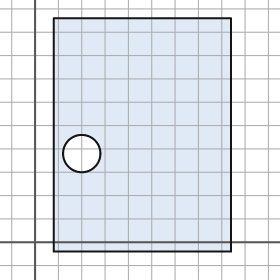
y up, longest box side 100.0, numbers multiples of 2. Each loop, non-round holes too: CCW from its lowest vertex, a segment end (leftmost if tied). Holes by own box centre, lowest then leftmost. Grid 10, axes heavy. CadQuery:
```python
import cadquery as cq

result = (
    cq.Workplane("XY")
    .moveTo(8.0, -4.0)
    .lineTo(84.0, -4.0)
    .lineTo(84.0, 96.0)
    .lineTo(8.0, 96.0)
    .close()
    .moveTo(20.0, 38.0)
    .circle(8.0)
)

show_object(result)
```